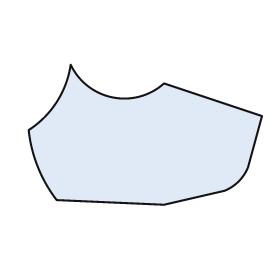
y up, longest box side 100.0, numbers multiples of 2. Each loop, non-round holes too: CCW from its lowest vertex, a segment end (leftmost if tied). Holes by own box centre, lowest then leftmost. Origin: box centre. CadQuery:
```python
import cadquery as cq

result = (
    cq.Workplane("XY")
    .moveTo(8.0, -30.0)
    .lineTo(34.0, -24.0)
    .threePointArc((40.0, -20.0), (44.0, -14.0))
    .lineTo(50.0, 8.0)
    .lineTo(8.0, 22.0)
    .threePointArc((-14.0, 16.0), (-32.0, 30.0))
    .threePointArc((-38.0, 14.0), (-50.0, 2.0))
    .threePointArc((-46.0, -14.0), (-38.0, -28.0))
    .close()
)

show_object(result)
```